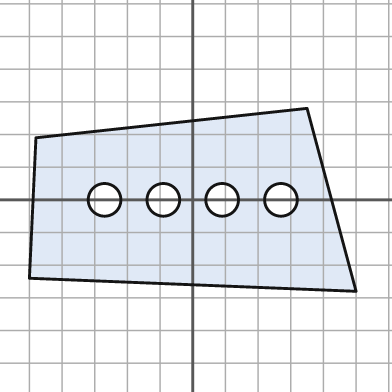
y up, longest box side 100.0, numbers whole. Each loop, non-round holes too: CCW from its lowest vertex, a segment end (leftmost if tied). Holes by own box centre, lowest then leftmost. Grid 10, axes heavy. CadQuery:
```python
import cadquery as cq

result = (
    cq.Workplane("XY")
    .moveTo(50.0, -28.0)
    .lineTo(35.0, 28.0)
    .lineTo(-48.0, 19.0)
    .lineTo(-50.0, -24.0)
    .close()
    .moveTo(-27.0, 0.0)
    .circle(5.0)
    .moveTo(-9.0, 0.0)
    .circle(5.0)
    .moveTo(9.0, 0.0)
    .circle(5.0)
    .moveTo(27.0, 0.0)
    .circle(5.0)
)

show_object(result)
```